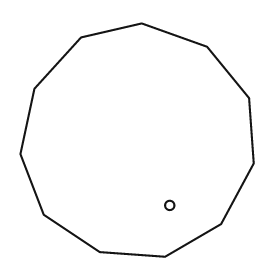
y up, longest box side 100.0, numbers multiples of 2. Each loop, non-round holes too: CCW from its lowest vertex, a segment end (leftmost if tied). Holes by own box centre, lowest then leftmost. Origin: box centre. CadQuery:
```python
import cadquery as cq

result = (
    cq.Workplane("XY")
    .moveTo(12.0, -50.0)
    .lineTo(36.0, -36.0)
    .lineTo(50.0, -10.0)
    .lineTo(48.0, 18.0)
    .lineTo(30.0, 40.0)
    .lineTo(2.0, 50.0)
    .lineTo(-24.0, 44.0)
    .lineTo(-44.0, 22.0)
    .lineTo(-50.0, -6.0)
    .lineTo(-40.0, -32.0)
    .lineTo(-16.0, -48.0)
    .close()
    .moveTo(14.0, -28.0)
    .circle(2.0)
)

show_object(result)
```